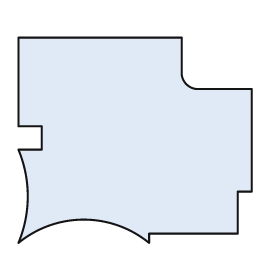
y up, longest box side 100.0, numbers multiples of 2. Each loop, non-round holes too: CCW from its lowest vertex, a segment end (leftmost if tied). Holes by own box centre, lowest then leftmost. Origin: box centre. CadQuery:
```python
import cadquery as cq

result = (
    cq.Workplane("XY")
    .moveTo(-50.0, -44.0)
    .threePointArc((-22.0, -34.0), (6.0, -44.0))
    .lineTo(6.0, -40.0)
    .lineTo(44.0, -40.0)
    .lineTo(44.0, -22.0)
    .lineTo(50.0, -22.0)
    .lineTo(50.0, 22.0)
    .lineTo(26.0, 22.0)
    .threePointArc((22.0, 24.0), (20.0, 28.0))
    .lineTo(20.0, 44.0)
    .lineTo(-50.0, 44.0)
    .lineTo(-50.0, 6.0)
    .lineTo(-40.0, 6.0)
    .lineTo(-40.0, -4.0)
    .lineTo(-50.0, -4.0)
    .threePointArc((-46.0, -24.0), (-50.0, -44.0))
    .close()
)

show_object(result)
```